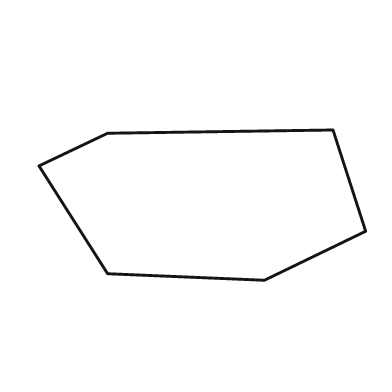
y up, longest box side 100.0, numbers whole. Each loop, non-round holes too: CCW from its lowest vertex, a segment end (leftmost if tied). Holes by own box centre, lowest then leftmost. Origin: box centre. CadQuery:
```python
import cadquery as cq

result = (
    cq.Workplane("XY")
    .moveTo(19.0, -23.0)
    .lineTo(50.0, -8.0)
    .lineTo(40.0, 23.0)
    .lineTo(-29.0, 22.0)
    .lineTo(-50.0, 12.0)
    .lineTo(-29.0, -21.0)
    .close()
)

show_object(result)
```